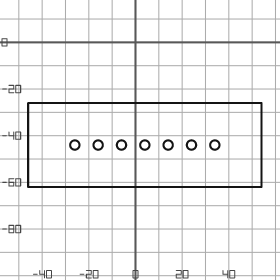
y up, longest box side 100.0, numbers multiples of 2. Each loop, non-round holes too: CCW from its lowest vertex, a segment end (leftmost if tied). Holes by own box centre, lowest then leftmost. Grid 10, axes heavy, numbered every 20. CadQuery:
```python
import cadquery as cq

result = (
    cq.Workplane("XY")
    .moveTo(-46.0, -62.0)
    .lineTo(54.0, -62.0)
    .lineTo(54.0, -26.0)
    .lineTo(-46.0, -26.0)
    .close()
    .moveTo(-26.0, -44.0)
    .circle(2.0)
    .moveTo(-16.0, -44.0)
    .circle(2.0)
    .moveTo(-6.0, -44.0)
    .circle(2.0)
    .moveTo(4.0, -44.0)
    .circle(2.0)
    .moveTo(14.0, -44.0)
    .circle(2.0)
    .moveTo(24.0, -44.0)
    .circle(2.0)
    .moveTo(34.0, -44.0)
    .circle(2.0)
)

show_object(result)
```